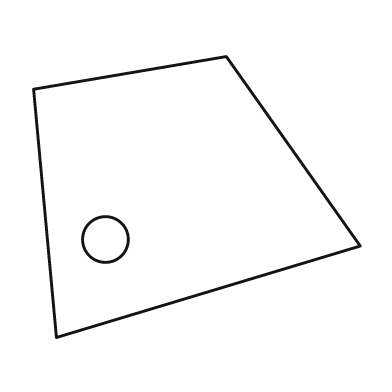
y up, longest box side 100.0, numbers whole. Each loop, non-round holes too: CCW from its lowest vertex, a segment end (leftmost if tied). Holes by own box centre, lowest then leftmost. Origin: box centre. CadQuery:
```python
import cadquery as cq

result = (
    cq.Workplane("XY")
    .moveTo(-43.0, -43.0)
    .lineTo(50.0, -15.0)
    .lineTo(9.0, 43.0)
    .lineTo(-50.0, 33.0)
    .close()
    .moveTo(-28.0, -13.0)
    .circle(7.0)
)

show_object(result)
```